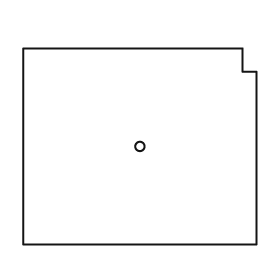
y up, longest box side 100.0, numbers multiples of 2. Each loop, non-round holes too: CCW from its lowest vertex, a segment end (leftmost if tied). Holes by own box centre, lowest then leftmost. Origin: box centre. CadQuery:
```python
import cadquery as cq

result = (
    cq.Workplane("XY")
    .moveTo(-50.0, -42.0)
    .lineTo(50.0, -42.0)
    .lineTo(50.0, 32.0)
    .lineTo(44.0, 32.0)
    .lineTo(44.0, 42.0)
    .lineTo(-50.0, 42.0)
    .close()
    .moveTo(0.0, 0.0)
    .circle(2.0)
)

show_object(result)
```